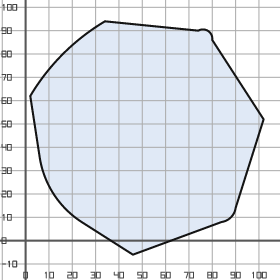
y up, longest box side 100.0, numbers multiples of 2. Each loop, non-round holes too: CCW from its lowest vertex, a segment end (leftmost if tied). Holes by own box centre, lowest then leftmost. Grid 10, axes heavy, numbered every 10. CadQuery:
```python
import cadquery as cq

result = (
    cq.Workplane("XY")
    .moveTo(46.0, -6.0)
    .lineTo(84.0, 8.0)
    .threePointArc((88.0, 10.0), (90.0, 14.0))
    .lineTo(102.0, 52.0)
    .lineTo(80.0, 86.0)
    .threePointArc((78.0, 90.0), (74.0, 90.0))
    .lineTo(34.0, 94.0)
    .threePointArc((16.0, 80.0), (2.0, 62.0))
    .lineTo(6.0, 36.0)
    .threePointArc((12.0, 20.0), (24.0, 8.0))
    .close()
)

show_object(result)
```